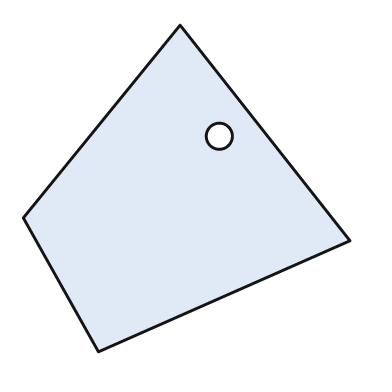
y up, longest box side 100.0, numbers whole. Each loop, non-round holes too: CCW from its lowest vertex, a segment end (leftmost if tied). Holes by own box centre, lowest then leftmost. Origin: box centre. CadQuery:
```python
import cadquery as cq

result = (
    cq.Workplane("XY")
    .moveTo(-27.0, -50.0)
    .lineTo(50.0, -16.0)
    .lineTo(-2.0, 50.0)
    .lineTo(-50.0, -9.0)
    .close()
    .moveTo(10.0, 16.0)
    .circle(4.0)
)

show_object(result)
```